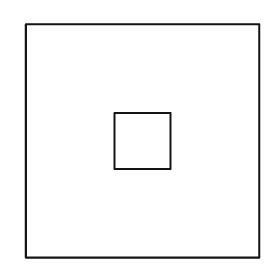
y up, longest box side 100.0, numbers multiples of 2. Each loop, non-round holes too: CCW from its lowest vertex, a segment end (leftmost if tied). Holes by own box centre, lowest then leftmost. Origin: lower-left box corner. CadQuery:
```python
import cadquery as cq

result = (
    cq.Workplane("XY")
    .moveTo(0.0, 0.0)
    .lineTo(100.0, 0.0)
    .lineTo(100.0, 100.0)
    .lineTo(0.0, 100.0)
    .close()
    .moveTo(38.0, 38.0)
    .lineTo(62.0, 38.0)
    .lineTo(62.0, 62.0)
    .lineTo(38.0, 62.0)
    .close()
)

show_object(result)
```